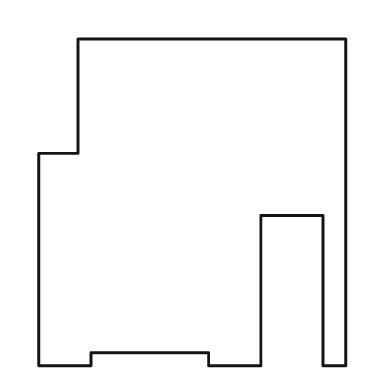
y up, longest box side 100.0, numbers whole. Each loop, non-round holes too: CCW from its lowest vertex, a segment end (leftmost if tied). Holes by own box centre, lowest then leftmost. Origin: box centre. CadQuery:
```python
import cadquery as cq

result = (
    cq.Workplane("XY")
    .moveTo(-47.0, -50.0)
    .lineTo(-31.0, -50.0)
    .lineTo(-31.0, -46.0)
    .lineTo(5.0, -46.0)
    .lineTo(5.0, -50.0)
    .lineTo(21.0, -50.0)
    .lineTo(21.0, -4.0)
    .lineTo(40.0, -4.0)
    .lineTo(40.0, -50.0)
    .lineTo(47.0, -50.0)
    .lineTo(47.0, 50.0)
    .lineTo(-35.0, 50.0)
    .lineTo(-35.0, 15.0)
    .lineTo(-47.0, 15.0)
    .close()
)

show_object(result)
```